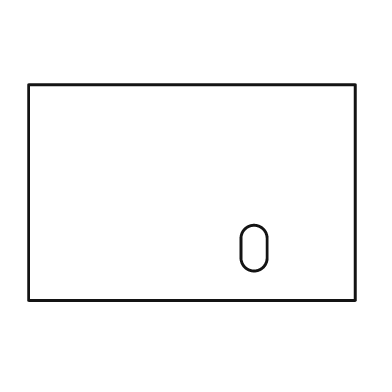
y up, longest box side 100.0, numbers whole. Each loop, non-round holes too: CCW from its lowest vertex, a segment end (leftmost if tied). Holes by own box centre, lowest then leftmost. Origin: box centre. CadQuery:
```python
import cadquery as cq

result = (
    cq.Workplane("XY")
    .moveTo(-50.0, -33.0)
    .lineTo(50.0, -33.0)
    .lineTo(50.0, 33.0)
    .lineTo(-50.0, 33.0)
    .close()
    .moveTo(15.0, -20.0)
    .threePointArc((19.0, -24.0), (23.0, -20.0))
    .lineTo(23.0, -14.0)
    .threePointArc((19.0, -10.0), (15.0, -14.0))
    .close()
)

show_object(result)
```